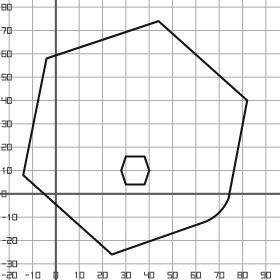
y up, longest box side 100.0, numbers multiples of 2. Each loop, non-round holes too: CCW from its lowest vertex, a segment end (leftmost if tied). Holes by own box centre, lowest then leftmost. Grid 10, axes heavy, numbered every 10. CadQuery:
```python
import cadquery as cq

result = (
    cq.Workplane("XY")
    .moveTo(24.0, -26.0)
    .lineTo(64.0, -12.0)
    .threePointArc((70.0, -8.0), (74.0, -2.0))
    .lineTo(82.0, 40.0)
    .lineTo(44.0, 74.0)
    .lineTo(-4.0, 58.0)
    .lineTo(-14.0, 8.0)
    .close()
    .moveTo(30.0, 4.0)
    .lineTo(38.0, 4.0)
    .lineTo(40.0, 10.0)
    .lineTo(38.0, 16.0)
    .lineTo(30.0, 16.0)
    .lineTo(28.0, 10.0)
    .close()
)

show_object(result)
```